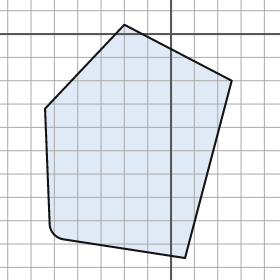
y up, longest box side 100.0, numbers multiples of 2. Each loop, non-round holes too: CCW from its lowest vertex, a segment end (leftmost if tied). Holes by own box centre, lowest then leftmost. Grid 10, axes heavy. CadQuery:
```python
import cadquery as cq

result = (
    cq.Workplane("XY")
    .moveTo(6.0, -96.0)
    .lineTo(26.0, -20.0)
    .lineTo(-20.0, 4.0)
    .lineTo(-54.0, -32.0)
    .lineTo(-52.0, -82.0)
    .threePointArc((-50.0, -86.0), (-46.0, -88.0))
    .close()
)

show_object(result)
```